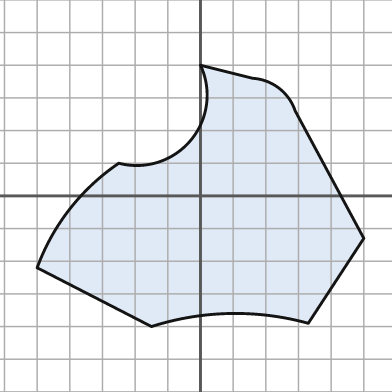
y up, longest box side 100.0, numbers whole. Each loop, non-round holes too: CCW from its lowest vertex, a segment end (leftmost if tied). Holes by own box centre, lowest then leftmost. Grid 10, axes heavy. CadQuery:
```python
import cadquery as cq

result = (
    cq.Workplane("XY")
    .moveTo(-15.0, -40.0)
    .threePointArc((9.0, -36.0), (33.0, -39.0))
    .lineTo(50.0, -13.0)
    .lineTo(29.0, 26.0)
    .threePointArc((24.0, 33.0), (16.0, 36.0))
    .lineTo(0.0, 40.0)
    .threePointArc((-3.0, 17.0), (-25.0, 10.0))
    .threePointArc((-40.0, -4.0), (-50.0, -22.0))
    .close()
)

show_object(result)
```